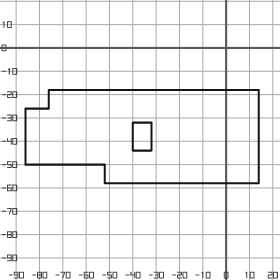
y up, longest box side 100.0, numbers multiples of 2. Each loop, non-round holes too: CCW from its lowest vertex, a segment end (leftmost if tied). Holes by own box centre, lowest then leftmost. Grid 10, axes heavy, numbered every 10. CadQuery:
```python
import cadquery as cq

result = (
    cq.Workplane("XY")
    .moveTo(-52.0, -58.0)
    .lineTo(14.0, -58.0)
    .lineTo(14.0, -18.0)
    .lineTo(-76.0, -18.0)
    .lineTo(-76.0, -26.0)
    .lineTo(-86.0, -26.0)
    .lineTo(-86.0, -50.0)
    .lineTo(-52.0, -50.0)
    .close()
    .moveTo(-40.0, -44.0)
    .lineTo(-32.0, -44.0)
    .lineTo(-32.0, -32.0)
    .lineTo(-40.0, -32.0)
    .close()
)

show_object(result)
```